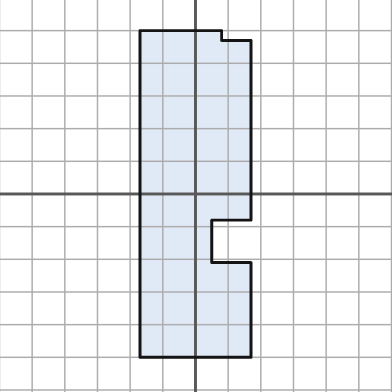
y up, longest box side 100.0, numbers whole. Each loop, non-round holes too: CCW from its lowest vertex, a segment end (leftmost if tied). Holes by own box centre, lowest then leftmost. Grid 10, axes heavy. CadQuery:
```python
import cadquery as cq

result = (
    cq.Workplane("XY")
    .moveTo(-17.0, -50.0)
    .lineTo(17.0, -50.0)
    .lineTo(17.0, -21.0)
    .lineTo(5.0, -21.0)
    .lineTo(5.0, -8.0)
    .lineTo(17.0, -8.0)
    .lineTo(17.0, 47.0)
    .lineTo(8.0, 47.0)
    .lineTo(8.0, 50.0)
    .lineTo(-17.0, 50.0)
    .close()
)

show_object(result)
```